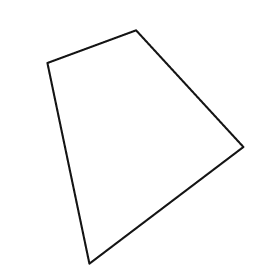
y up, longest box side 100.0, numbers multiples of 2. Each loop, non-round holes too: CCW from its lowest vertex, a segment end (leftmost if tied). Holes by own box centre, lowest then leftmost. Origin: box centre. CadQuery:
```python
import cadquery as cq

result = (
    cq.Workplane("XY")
    .moveTo(-24.0, -50.0)
    .lineTo(42.0, 0.0)
    .lineTo(-4.0, 50.0)
    .lineTo(-42.0, 36.0)
    .close()
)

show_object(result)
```